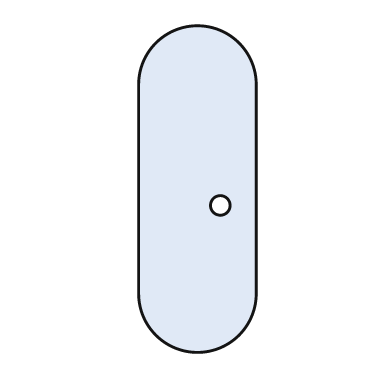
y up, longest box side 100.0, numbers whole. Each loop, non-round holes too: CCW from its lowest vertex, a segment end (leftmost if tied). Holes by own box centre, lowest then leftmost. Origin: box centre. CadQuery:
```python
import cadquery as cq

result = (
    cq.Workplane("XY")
    .moveTo(-18.0, -32.0)
    .threePointArc((0.0, -50.0), (18.0, -32.0))
    .lineTo(18.0, 32.0)
    .threePointArc((0.0, 50.0), (-18.0, 32.0))
    .close()
    .moveTo(7.0, -5.0)
    .circle(3.0)
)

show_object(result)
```